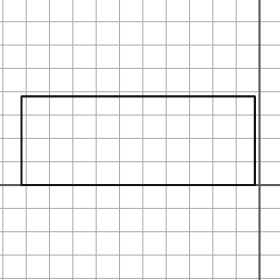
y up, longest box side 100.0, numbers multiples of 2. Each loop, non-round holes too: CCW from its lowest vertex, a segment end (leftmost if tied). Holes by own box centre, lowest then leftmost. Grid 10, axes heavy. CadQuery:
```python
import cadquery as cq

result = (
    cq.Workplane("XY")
    .moveTo(-102.0, 0.0)
    .lineTo(-2.0, 0.0)
    .lineTo(-2.0, 38.0)
    .lineTo(-102.0, 38.0)
    .close()
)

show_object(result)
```